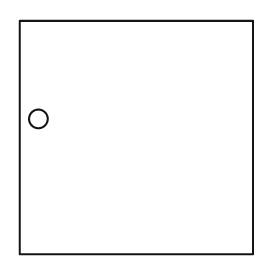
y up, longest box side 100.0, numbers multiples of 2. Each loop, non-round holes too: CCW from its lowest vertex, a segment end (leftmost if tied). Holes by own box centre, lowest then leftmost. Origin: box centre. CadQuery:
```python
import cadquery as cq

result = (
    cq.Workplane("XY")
    .moveTo(-50.0, -50.0)
    .lineTo(50.0, -50.0)
    .lineTo(50.0, 50.0)
    .lineTo(-50.0, 50.0)
    .close()
    .moveTo(-42.0, 8.0)
    .circle(4.0)
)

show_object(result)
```